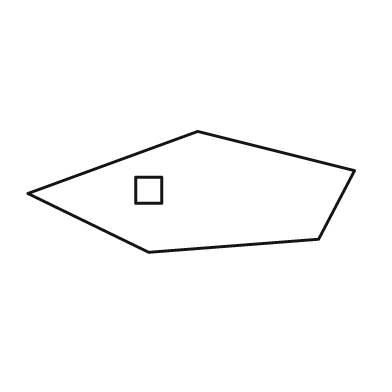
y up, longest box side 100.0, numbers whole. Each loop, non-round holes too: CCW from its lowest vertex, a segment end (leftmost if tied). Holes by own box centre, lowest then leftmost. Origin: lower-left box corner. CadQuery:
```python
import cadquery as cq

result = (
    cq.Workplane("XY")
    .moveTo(37.0, 0.0)
    .lineTo(89.0, 4.0)
    .lineTo(100.0, 25.0)
    .lineTo(52.0, 37.0)
    .lineTo(0.0, 18.0)
    .close()
    .moveTo(33.0, 15.0)
    .lineTo(41.0, 15.0)
    .lineTo(41.0, 23.0)
    .lineTo(33.0, 23.0)
    .close()
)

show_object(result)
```